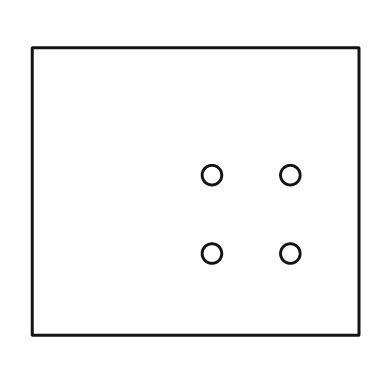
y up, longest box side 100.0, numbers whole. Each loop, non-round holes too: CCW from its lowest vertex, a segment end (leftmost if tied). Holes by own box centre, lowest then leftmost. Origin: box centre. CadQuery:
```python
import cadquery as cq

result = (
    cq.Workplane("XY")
    .moveTo(-50.0, -44.0)
    .lineTo(50.0, -44.0)
    .lineTo(50.0, 44.0)
    .lineTo(-50.0, 44.0)
    .close()
    .moveTo(5.0, -19.0)
    .circle(3.0)
    .moveTo(29.0, -19.0)
    .circle(3.0)
    .moveTo(5.0, 5.0)
    .circle(3.0)
    .moveTo(29.0, 5.0)
    .circle(3.0)
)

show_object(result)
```